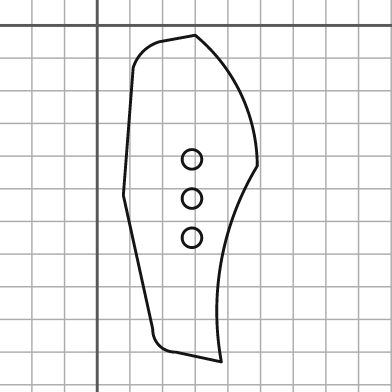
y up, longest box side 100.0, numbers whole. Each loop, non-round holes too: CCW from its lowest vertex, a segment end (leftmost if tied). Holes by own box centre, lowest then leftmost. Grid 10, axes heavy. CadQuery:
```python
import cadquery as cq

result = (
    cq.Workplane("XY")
    .moveTo(38.0, -103.0)
    .threePointArc((38.0, -72.0), (49.0, -43.0))
    .threePointArc((44.0, -21.0), (30.0, -3.0))
    .lineTo(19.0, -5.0)
    .threePointArc((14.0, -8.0), (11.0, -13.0))
    .lineTo(8.0, -52.0)
    .lineTo(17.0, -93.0)
    .threePointArc((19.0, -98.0), (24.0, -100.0))
    .close()
    .moveTo(29.0, -65.0)
    .circle(3.0)
    .moveTo(29.0, -53.0)
    .circle(3.0)
    .moveTo(29.0, -41.0)
    .circle(3.0)
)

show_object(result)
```